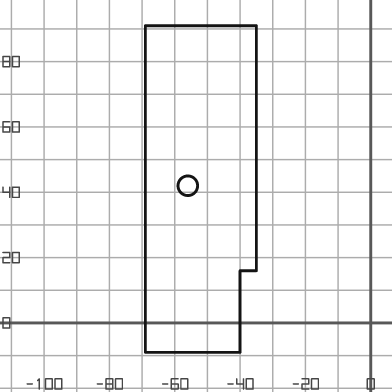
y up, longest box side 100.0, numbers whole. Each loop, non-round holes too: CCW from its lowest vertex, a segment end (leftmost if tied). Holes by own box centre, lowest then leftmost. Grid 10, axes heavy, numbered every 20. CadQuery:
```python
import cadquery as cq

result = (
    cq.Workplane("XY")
    .moveTo(-69.0, -9.0)
    .lineTo(-40.0, -9.0)
    .lineTo(-40.0, 16.0)
    .lineTo(-35.0, 16.0)
    .lineTo(-35.0, 91.0)
    .lineTo(-69.0, 91.0)
    .close()
    .moveTo(-56.0, 42.0)
    .circle(3.0)
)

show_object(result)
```